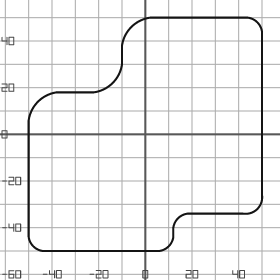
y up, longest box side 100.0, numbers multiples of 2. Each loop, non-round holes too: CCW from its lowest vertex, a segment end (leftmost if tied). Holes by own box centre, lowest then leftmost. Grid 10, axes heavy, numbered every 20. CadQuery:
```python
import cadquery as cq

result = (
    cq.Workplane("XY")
    .moveTo(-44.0, -50.0)
    .lineTo(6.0, -50.0)
    .threePointArc((10.0, -48.0), (12.0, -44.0))
    .lineTo(12.0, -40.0)
    .threePointArc((14.0, -36.0), (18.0, -34.0))
    .lineTo(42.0, -34.0)
    .threePointArc((48.0, -32.0), (50.0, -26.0))
    .lineTo(50.0, 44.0)
    .threePointArc((48.0, 48.0), (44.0, 50.0))
    .lineTo(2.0, 50.0)
    .threePointArc((-6.0, 46.0), (-10.0, 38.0))
    .lineTo(-10.0, 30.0)
    .threePointArc((-14.0, 22.0), (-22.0, 18.0))
    .lineTo(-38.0, 18.0)
    .threePointArc((-46.0, 14.0), (-50.0, 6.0))
    .lineTo(-50.0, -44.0)
    .threePointArc((-48.0, -48.0), (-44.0, -50.0))
    .close()
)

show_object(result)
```